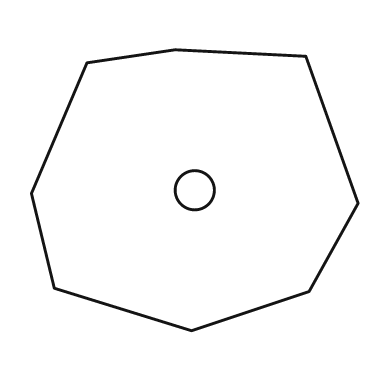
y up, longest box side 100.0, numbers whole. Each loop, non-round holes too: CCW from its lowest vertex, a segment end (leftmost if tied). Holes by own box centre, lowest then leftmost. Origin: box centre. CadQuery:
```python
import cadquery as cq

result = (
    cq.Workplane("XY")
    .moveTo(-1.0, -43.0)
    .lineTo(35.0, -31.0)
    .lineTo(50.0, -4.0)
    .lineTo(34.0, 41.0)
    .lineTo(-6.0, 43.0)
    .lineTo(-33.0, 39.0)
    .lineTo(-50.0, -1.0)
    .lineTo(-43.0, -30.0)
    .close()
    .moveTo(0.0, 0.0)
    .circle(6.0)
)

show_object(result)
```